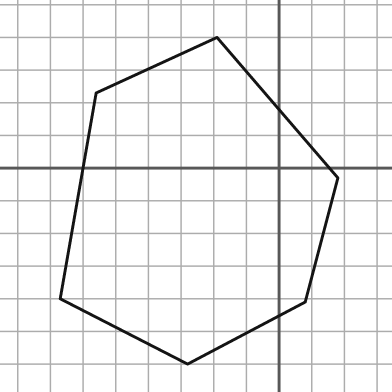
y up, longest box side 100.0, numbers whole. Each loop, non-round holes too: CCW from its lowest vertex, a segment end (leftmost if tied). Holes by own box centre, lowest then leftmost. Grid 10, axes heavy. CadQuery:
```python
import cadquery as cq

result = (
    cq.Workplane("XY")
    .moveTo(-28.0, -60.0)
    .lineTo(8.0, -41.0)
    .lineTo(18.0, -3.0)
    .lineTo(-19.0, 40.0)
    .lineTo(-56.0, 23.0)
    .lineTo(-67.0, -40.0)
    .close()
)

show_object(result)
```